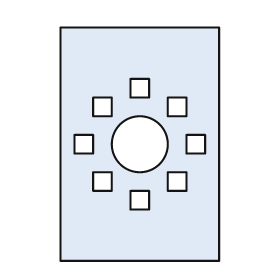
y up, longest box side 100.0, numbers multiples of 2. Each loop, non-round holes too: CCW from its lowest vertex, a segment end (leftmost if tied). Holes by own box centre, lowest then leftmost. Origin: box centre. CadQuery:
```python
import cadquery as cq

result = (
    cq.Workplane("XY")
    .moveTo(-34.0, -50.0)
    .lineTo(34.0, -50.0)
    .lineTo(34.0, 50.0)
    .lineTo(-34.0, 50.0)
    .close()
    .moveTo(-4.0, -28.0)
    .lineTo(4.0, -28.0)
    .lineTo(4.0, -20.0)
    .lineTo(-4.0, -20.0)
    .close()
    .moveTo(-20.0, -20.0)
    .lineTo(-12.0, -20.0)
    .lineTo(-12.0, -12.0)
    .lineTo(-20.0, -12.0)
    .close()
    .moveTo(12.0, -20.0)
    .lineTo(20.0, -20.0)
    .lineTo(20.0, -12.0)
    .lineTo(12.0, -12.0)
    .close()
    .moveTo(-28.0, -4.0)
    .lineTo(-20.0, -4.0)
    .lineTo(-20.0, 4.0)
    .lineTo(-28.0, 4.0)
    .close()
    .moveTo(0.0, 0.0)
    .circle(12.0)
    .moveTo(20.0, -4.0)
    .lineTo(28.0, -4.0)
    .lineTo(28.0, 4.0)
    .lineTo(20.0, 4.0)
    .close()
    .moveTo(-20.0, 12.0)
    .lineTo(-12.0, 12.0)
    .lineTo(-12.0, 20.0)
    .lineTo(-20.0, 20.0)
    .close()
    .moveTo(12.0, 12.0)
    .lineTo(20.0, 12.0)
    .lineTo(20.0, 20.0)
    .lineTo(12.0, 20.0)
    .close()
    .moveTo(-4.0, 20.0)
    .lineTo(4.0, 20.0)
    .lineTo(4.0, 28.0)
    .lineTo(-4.0, 28.0)
    .close()
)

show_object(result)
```